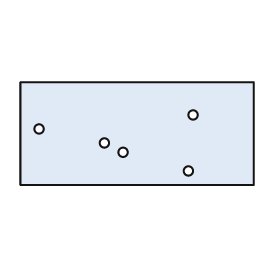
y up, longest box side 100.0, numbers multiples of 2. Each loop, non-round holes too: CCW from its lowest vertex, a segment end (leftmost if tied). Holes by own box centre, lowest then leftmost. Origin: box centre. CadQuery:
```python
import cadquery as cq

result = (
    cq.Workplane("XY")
    .moveTo(-50.0, -22.0)
    .lineTo(50.0, -22.0)
    .lineTo(50.0, 22.0)
    .lineTo(-50.0, 22.0)
    .close()
    .moveTo(22.0, -16.0)
    .circle(2.0)
    .moveTo(-6.0, -8.0)
    .circle(2.0)
    .moveTo(-14.0, -4.0)
    .circle(2.0)
    .moveTo(-42.0, 2.0)
    .circle(2.0)
    .moveTo(24.0, 8.0)
    .circle(2.0)
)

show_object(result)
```